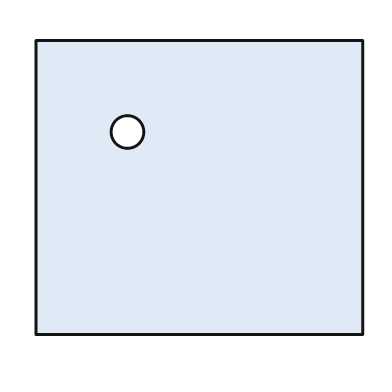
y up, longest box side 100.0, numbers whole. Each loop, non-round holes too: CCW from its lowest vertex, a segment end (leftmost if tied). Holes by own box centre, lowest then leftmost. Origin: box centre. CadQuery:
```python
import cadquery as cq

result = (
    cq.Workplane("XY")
    .moveTo(-50.0, -45.0)
    .lineTo(50.0, -45.0)
    .lineTo(50.0, 45.0)
    .lineTo(-50.0, 45.0)
    .close()
    .moveTo(-22.0, 17.0)
    .circle(5.0)
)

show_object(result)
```